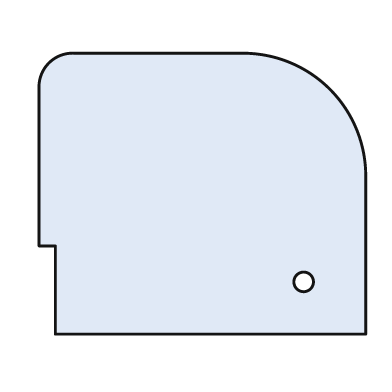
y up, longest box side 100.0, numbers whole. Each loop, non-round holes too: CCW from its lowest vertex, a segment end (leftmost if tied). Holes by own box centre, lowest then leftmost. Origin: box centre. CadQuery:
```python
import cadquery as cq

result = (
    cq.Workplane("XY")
    .moveTo(-45.0, -43.0)
    .lineTo(50.0, -43.0)
    .lineTo(50.0, 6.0)
    .threePointArc((39.0, 32.0), (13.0, 43.0))
    .lineTo(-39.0, 43.0)
    .threePointArc((-47.0, 40.0), (-50.0, 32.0))
    .lineTo(-50.0, -16.0)
    .lineTo(-45.0, -16.0)
    .close()
    .moveTo(31.0, -27.0)
    .circle(3.0)
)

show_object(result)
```